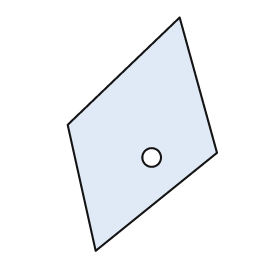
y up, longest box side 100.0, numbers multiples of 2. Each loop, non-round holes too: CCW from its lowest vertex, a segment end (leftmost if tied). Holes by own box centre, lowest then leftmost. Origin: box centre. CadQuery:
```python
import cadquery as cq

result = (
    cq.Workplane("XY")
    .moveTo(-20.0, -50.0)
    .lineTo(32.0, -8.0)
    .lineTo(16.0, 50.0)
    .lineTo(-32.0, 4.0)
    .close()
    .moveTo(4.0, -10.0)
    .circle(4.0)
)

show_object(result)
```